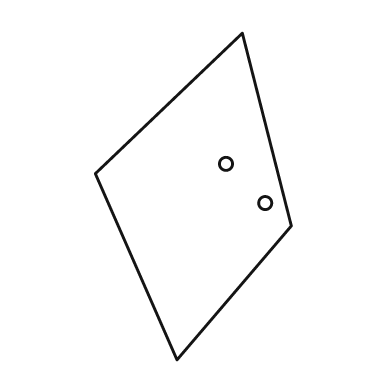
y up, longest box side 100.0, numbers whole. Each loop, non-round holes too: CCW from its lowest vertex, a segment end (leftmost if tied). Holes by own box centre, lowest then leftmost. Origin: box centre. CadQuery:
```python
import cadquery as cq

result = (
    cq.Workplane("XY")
    .moveTo(-5.0, -50.0)
    .lineTo(30.0, -9.0)
    .lineTo(15.0, 50.0)
    .lineTo(-30.0, 7.0)
    .close()
    .moveTo(22.0, -2.0)
    .circle(2.0)
    .moveTo(10.0, 10.0)
    .circle(2.0)
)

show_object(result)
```